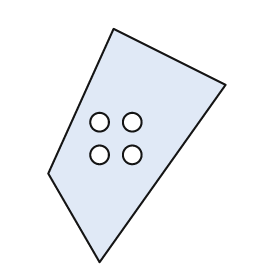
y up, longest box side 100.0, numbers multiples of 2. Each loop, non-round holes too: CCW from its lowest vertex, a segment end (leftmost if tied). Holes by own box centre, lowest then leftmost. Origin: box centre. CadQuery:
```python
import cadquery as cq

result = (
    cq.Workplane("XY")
    .moveTo(-16.0, -50.0)
    .lineTo(38.0, 26.0)
    .lineTo(-10.0, 50.0)
    .lineTo(-38.0, -12.0)
    .close()
    .moveTo(-16.0, -4.0)
    .circle(4.0)
    .moveTo(-2.0, -4.0)
    .circle(4.0)
    .moveTo(-16.0, 10.0)
    .circle(4.0)
    .moveTo(-2.0, 10.0)
    .circle(4.0)
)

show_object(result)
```